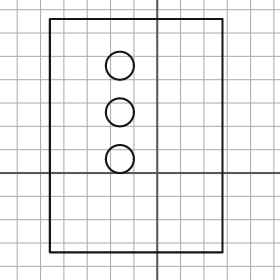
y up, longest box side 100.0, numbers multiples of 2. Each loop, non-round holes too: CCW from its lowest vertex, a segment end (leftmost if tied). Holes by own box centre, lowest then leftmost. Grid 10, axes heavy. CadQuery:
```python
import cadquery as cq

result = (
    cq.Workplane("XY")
    .moveTo(-46.0, -34.0)
    .lineTo(28.0, -34.0)
    .lineTo(28.0, 66.0)
    .lineTo(-46.0, 66.0)
    .close()
    .moveTo(-16.0, 6.0)
    .circle(6.0)
    .moveTo(-16.0, 26.0)
    .circle(6.0)
    .moveTo(-16.0, 46.0)
    .circle(6.0)
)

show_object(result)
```